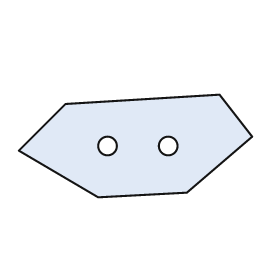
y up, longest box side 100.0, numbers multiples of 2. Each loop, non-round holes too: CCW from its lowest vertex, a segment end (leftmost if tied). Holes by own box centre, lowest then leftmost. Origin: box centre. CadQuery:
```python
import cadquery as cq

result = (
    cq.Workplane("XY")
    .moveTo(-16.0, -22.0)
    .lineTo(22.0, -20.0)
    .lineTo(50.0, 4.0)
    .lineTo(36.0, 22.0)
    .lineTo(-30.0, 18.0)
    .lineTo(-50.0, -2.0)
    .close()
    .moveTo(-12.0, 0.0)
    .circle(4.0)
    .moveTo(14.0, 0.0)
    .circle(4.0)
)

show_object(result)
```